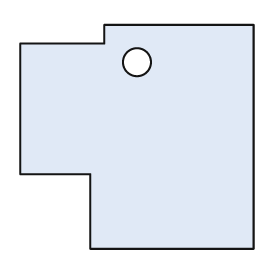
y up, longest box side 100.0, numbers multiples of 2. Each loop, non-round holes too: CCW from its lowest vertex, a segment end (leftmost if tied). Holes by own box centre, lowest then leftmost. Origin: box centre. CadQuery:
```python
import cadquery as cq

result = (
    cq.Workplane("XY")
    .moveTo(-20.0, -48.0)
    .lineTo(50.0, -48.0)
    .lineTo(50.0, 48.0)
    .lineTo(-14.0, 48.0)
    .lineTo(-14.0, 40.0)
    .lineTo(-50.0, 40.0)
    .lineTo(-50.0, -16.0)
    .lineTo(-20.0, -16.0)
    .close()
    .moveTo(0.0, 32.0)
    .circle(6.0)
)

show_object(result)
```